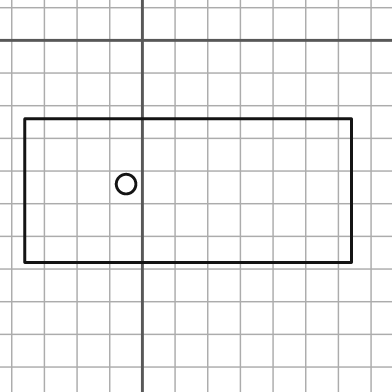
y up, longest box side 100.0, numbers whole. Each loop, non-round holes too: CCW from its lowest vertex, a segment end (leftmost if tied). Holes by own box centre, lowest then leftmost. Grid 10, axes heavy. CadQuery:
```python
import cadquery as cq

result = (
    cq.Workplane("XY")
    .moveTo(-36.0, -68.0)
    .lineTo(64.0, -68.0)
    .lineTo(64.0, -24.0)
    .lineTo(-36.0, -24.0)
    .close()
    .moveTo(-5.0, -44.0)
    .circle(3.0)
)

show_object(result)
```